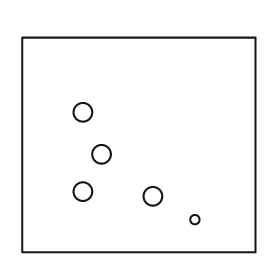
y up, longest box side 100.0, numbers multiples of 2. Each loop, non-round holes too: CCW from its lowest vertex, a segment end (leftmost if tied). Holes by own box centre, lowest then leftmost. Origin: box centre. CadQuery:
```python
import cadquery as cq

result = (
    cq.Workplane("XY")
    .moveTo(-50.0, -46.0)
    .lineTo(50.0, -46.0)
    .lineTo(50.0, 46.0)
    .lineTo(-50.0, 46.0)
    .close()
    .moveTo(24.0, -32.0)
    .circle(2.0)
    .moveTo(6.0, -22.0)
    .circle(4.0)
    .moveTo(-24.0, -20.0)
    .circle(4.0)
    .moveTo(-16.0, -4.0)
    .circle(4.0)
    .moveTo(-24.0, 14.0)
    .circle(4.0)
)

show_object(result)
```